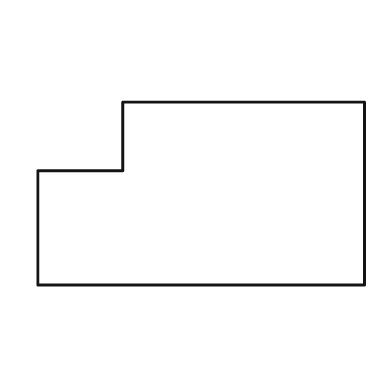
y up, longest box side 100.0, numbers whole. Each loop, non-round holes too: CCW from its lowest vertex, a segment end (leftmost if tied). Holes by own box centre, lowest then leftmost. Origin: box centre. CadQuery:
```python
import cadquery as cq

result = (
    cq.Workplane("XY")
    .moveTo(-50.0, -28.0)
    .lineTo(50.0, -28.0)
    .lineTo(50.0, 28.0)
    .lineTo(-24.0, 28.0)
    .lineTo(-24.0, 7.0)
    .lineTo(-50.0, 7.0)
    .close()
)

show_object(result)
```